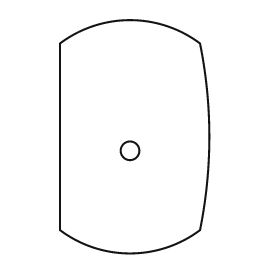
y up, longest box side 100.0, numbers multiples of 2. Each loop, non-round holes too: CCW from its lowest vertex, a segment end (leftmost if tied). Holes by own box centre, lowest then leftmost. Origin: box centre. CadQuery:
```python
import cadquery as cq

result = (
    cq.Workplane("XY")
    .moveTo(-32.0, -40.0)
    .threePointArc((-2.0, -50.0), (28.0, -40.0))
    .threePointArc((32.0, 0.0), (28.0, 40.0))
    .threePointArc((-2.0, 50.0), (-32.0, 40.0))
    .close()
    .moveTo(-2.0, -6.0)
    .circle(4.0)
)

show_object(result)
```